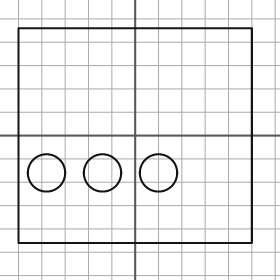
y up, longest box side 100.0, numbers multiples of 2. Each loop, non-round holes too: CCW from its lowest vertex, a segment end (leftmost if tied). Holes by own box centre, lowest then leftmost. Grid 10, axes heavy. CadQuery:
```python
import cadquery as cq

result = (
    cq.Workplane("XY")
    .moveTo(-50.0, -46.0)
    .lineTo(50.0, -46.0)
    .lineTo(50.0, 46.0)
    .lineTo(-50.0, 46.0)
    .close()
    .moveTo(-38.0, -16.0)
    .circle(8.0)
    .moveTo(-14.0, -16.0)
    .circle(8.0)
    .moveTo(10.0, -16.0)
    .circle(8.0)
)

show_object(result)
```